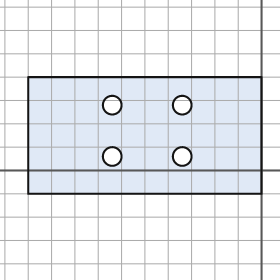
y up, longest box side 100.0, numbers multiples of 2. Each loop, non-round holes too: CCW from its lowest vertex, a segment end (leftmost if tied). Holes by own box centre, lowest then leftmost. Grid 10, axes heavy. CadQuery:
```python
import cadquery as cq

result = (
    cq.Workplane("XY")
    .moveTo(-100.0, -10.0)
    .lineTo(0.0, -10.0)
    .lineTo(0.0, 40.0)
    .lineTo(-100.0, 40.0)
    .close()
    .moveTo(-64.0, 6.0)
    .circle(4.0)
    .moveTo(-34.0, 6.0)
    .circle(4.0)
    .moveTo(-64.0, 28.0)
    .circle(4.0)
    .moveTo(-34.0, 28.0)
    .circle(4.0)
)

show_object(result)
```